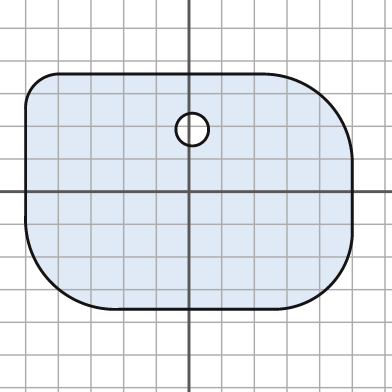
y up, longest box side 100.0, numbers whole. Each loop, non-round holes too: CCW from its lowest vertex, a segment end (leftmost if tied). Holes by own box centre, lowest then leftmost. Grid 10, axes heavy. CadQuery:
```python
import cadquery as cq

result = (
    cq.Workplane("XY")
    .moveTo(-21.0, -36.0)
    .lineTo(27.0, -36.0)
    .threePointArc((43.0, -29.0), (50.0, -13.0))
    .lineTo(50.0, 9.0)
    .threePointArc((42.0, 28.0), (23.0, 36.0))
    .lineTo(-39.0, 36.0)
    .threePointArc((-47.0, 33.0), (-50.0, 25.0))
    .lineTo(-50.0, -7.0)
    .threePointArc((-42.0, -28.0), (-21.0, -36.0))
    .close()
    .moveTo(1.0, 19.0)
    .circle(5.0)
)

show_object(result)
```